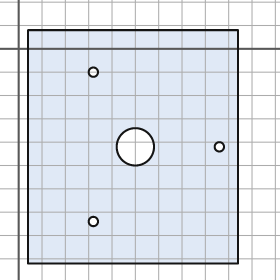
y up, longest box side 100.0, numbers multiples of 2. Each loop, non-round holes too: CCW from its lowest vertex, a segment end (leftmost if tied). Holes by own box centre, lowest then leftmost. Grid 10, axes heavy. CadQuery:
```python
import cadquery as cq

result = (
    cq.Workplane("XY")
    .moveTo(4.0, -92.0)
    .lineTo(94.0, -92.0)
    .lineTo(94.0, 8.0)
    .lineTo(4.0, 8.0)
    .close()
    .moveTo(32.0, -74.0)
    .circle(2.0)
    .moveTo(50.0, -42.0)
    .circle(8.0)
    .moveTo(86.0, -42.0)
    .circle(2.0)
    .moveTo(32.0, -10.0)
    .circle(2.0)
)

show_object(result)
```